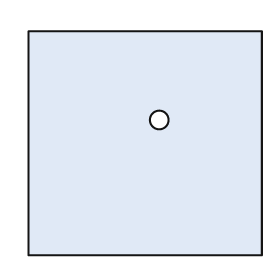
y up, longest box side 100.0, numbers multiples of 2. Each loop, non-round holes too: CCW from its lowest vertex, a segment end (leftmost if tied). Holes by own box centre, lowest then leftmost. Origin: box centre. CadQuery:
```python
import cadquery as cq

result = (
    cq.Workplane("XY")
    .moveTo(-50.0, -48.0)
    .lineTo(50.0, -48.0)
    .lineTo(50.0, 48.0)
    .lineTo(-50.0, 48.0)
    .close()
    .moveTo(6.0, 10.0)
    .circle(4.0)
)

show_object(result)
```